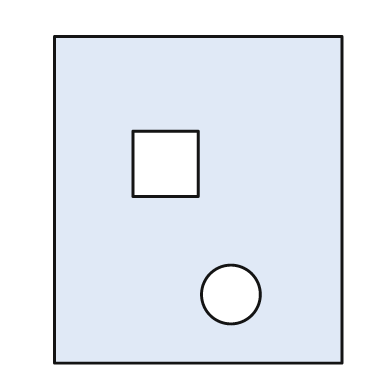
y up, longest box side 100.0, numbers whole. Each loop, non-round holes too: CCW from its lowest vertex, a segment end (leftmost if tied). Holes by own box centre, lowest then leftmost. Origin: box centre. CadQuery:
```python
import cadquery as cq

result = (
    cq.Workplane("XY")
    .moveTo(-44.0, -50.0)
    .lineTo(44.0, -50.0)
    .lineTo(44.0, 50.0)
    .lineTo(-44.0, 50.0)
    .close()
    .moveTo(10.0, -29.0)
    .circle(9.0)
    .moveTo(-20.0, 1.0)
    .lineTo(0.0, 1.0)
    .lineTo(0.0, 21.0)
    .lineTo(-20.0, 21.0)
    .close()
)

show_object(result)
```